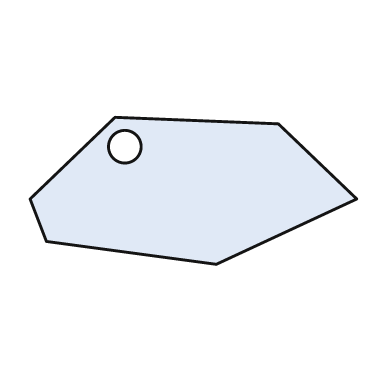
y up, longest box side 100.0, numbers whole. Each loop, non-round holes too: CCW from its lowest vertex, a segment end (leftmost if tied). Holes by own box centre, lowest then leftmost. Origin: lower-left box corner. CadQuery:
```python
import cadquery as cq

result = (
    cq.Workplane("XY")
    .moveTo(57.0, 0.0)
    .lineTo(100.0, 20.0)
    .lineTo(76.0, 43.0)
    .lineTo(26.0, 45.0)
    .lineTo(0.0, 20.0)
    .lineTo(5.0, 7.0)
    .close()
    .moveTo(29.0, 36.0)
    .circle(5.0)
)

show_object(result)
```